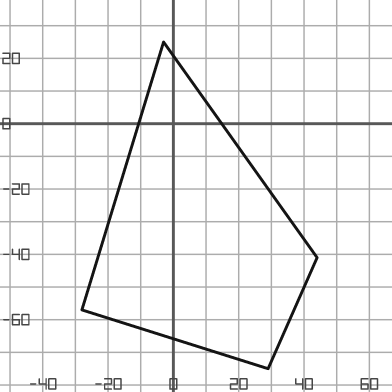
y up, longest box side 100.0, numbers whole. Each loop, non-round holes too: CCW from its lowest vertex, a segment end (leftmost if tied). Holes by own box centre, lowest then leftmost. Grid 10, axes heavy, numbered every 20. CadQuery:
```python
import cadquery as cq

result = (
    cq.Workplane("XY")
    .moveTo(29.0, -75.0)
    .lineTo(44.0, -41.0)
    .lineTo(-3.0, 25.0)
    .lineTo(-28.0, -57.0)
    .close()
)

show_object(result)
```